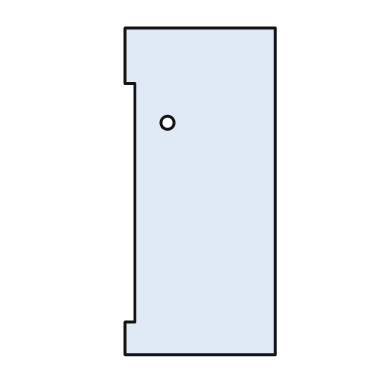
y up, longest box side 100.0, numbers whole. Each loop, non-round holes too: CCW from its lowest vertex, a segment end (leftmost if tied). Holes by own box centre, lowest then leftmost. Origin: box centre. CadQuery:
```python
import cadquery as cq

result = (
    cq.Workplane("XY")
    .moveTo(-23.0, -50.0)
    .lineTo(23.0, -50.0)
    .lineTo(23.0, 50.0)
    .lineTo(-23.0, 50.0)
    .lineTo(-23.0, 33.0)
    .lineTo(-20.0, 33.0)
    .lineTo(-20.0, -40.0)
    .lineTo(-23.0, -40.0)
    .close()
    .moveTo(-10.0, 21.0)
    .circle(2.0)
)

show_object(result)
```